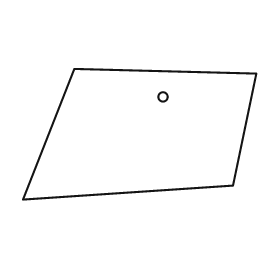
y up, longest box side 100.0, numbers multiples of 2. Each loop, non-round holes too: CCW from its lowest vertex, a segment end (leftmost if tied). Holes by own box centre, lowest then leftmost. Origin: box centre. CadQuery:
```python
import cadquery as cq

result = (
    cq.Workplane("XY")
    .moveTo(-50.0, -28.0)
    .lineTo(40.0, -22.0)
    .lineTo(50.0, 26.0)
    .lineTo(-28.0, 28.0)
    .close()
    .moveTo(10.0, 16.0)
    .circle(2.0)
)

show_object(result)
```